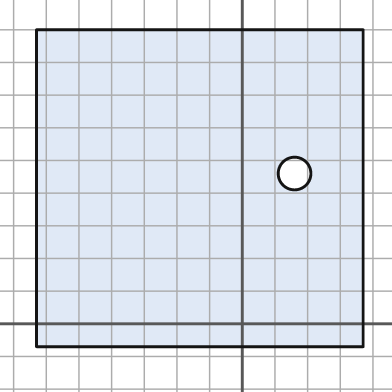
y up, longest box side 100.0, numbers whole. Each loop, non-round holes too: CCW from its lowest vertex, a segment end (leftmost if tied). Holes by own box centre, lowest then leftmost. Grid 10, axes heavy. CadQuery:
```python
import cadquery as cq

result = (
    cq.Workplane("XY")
    .moveTo(-63.0, -7.0)
    .lineTo(37.0, -7.0)
    .lineTo(37.0, 90.0)
    .lineTo(-63.0, 90.0)
    .close()
    .moveTo(16.0, 46.0)
    .circle(5.0)
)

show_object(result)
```